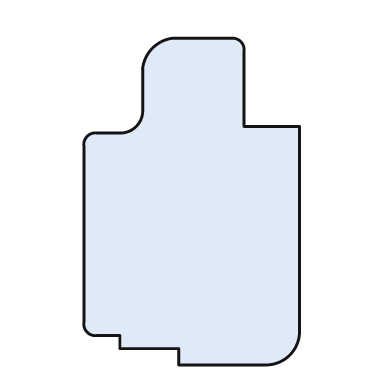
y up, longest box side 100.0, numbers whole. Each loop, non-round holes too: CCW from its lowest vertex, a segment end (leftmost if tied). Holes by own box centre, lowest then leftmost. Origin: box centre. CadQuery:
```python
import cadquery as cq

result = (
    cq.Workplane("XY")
    .moveTo(-4.0, -50.0)
    .lineTo(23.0, -50.0)
    .threePointArc((30.0, -47.0), (33.0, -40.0))
    .lineTo(33.0, 23.0)
    .lineTo(16.0, 23.0)
    .lineTo(16.0, 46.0)
    .threePointArc((15.0, 49.0), (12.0, 50.0))
    .lineTo(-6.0, 50.0)
    .threePointArc((-12.0, 47.0), (-15.0, 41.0))
    .lineTo(-15.0, 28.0)
    .threePointArc((-17.0, 23.0), (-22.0, 21.0))
    .lineTo(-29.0, 21.0)
    .threePointArc((-32.0, 20.0), (-33.0, 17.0))
    .lineTo(-33.0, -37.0)
    .threePointArc((-32.0, -40.0), (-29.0, -41.0))
    .lineTo(-22.0, -41.0)
    .lineTo(-22.0, -45.0)
    .lineTo(-4.0, -45.0)
    .close()
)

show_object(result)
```